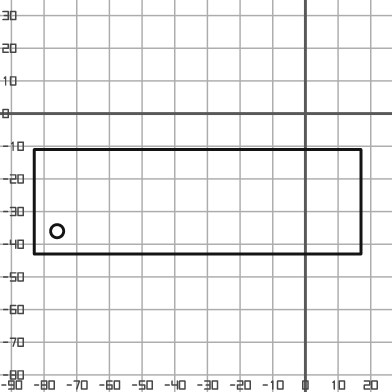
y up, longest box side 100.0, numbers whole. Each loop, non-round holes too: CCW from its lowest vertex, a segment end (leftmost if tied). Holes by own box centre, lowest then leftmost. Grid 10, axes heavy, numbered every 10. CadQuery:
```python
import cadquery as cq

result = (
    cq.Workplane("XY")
    .moveTo(-83.0, -43.0)
    .lineTo(17.0, -43.0)
    .lineTo(17.0, -11.0)
    .lineTo(-83.0, -11.0)
    .close()
    .moveTo(-76.0, -36.0)
    .circle(2.0)
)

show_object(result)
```